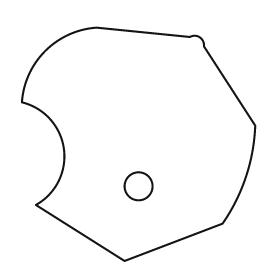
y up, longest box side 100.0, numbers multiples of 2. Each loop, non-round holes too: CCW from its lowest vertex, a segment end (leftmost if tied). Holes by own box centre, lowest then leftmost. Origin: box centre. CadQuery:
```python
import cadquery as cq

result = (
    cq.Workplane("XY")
    .moveTo(-6.0, -50.0)
    .lineTo(36.0, -34.0)
    .threePointArc((46.0, -14.0), (50.0, 8.0))
    .lineTo(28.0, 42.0)
    .threePointArc((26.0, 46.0), (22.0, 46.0))
    .lineTo(-18.0, 50.0)
    .threePointArc((-40.0, 40.0), (-50.0, 18.0))
    .threePointArc((-32.0, -2.0), (-44.0, -26.0))
    .close()
    .moveTo(0.0, -18.0)
    .circle(6.0)
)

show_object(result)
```